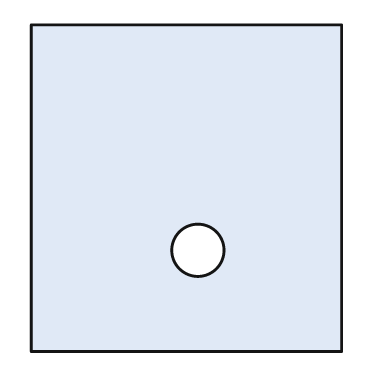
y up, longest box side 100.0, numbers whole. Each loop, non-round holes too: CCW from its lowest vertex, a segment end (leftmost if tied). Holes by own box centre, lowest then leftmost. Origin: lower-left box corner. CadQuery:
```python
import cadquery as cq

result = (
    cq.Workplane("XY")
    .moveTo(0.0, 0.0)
    .lineTo(95.0, 0.0)
    .lineTo(95.0, 100.0)
    .lineTo(0.0, 100.0)
    .close()
    .moveTo(51.0, 31.0)
    .circle(8.0)
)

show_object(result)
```